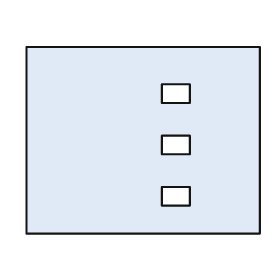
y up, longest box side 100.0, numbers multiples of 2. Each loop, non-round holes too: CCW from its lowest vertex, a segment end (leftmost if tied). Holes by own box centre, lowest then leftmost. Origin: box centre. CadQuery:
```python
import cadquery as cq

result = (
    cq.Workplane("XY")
    .moveTo(-50.0, -40.0)
    .lineTo(50.0, -40.0)
    .lineTo(50.0, 40.0)
    .lineTo(-50.0, 40.0)
    .close()
    .moveTo(8.0, -28.0)
    .lineTo(20.0, -28.0)
    .lineTo(20.0, -20.0)
    .lineTo(8.0, -20.0)
    .close()
    .moveTo(8.0, -6.0)
    .lineTo(20.0, -6.0)
    .lineTo(20.0, 2.0)
    .lineTo(8.0, 2.0)
    .close()
    .moveTo(8.0, 16.0)
    .lineTo(20.0, 16.0)
    .lineTo(20.0, 24.0)
    .lineTo(8.0, 24.0)
    .close()
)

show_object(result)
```